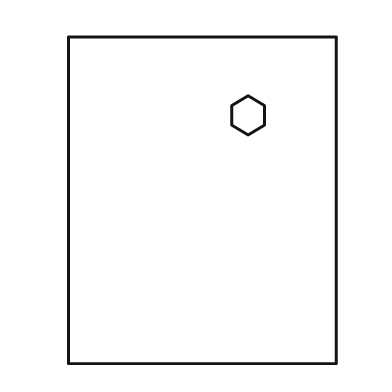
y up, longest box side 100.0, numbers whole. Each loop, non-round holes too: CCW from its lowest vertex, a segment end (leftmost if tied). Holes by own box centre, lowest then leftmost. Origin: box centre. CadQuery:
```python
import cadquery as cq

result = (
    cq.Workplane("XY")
    .moveTo(-41.0, -50.0)
    .lineTo(41.0, -50.0)
    .lineTo(41.0, 50.0)
    .lineTo(-41.0, 50.0)
    .close()
    .moveTo(14.0, 20.0)
    .lineTo(19.0, 23.0)
    .lineTo(19.0, 29.0)
    .lineTo(14.0, 32.0)
    .lineTo(9.0, 29.0)
    .lineTo(9.0, 23.0)
    .close()
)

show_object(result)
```